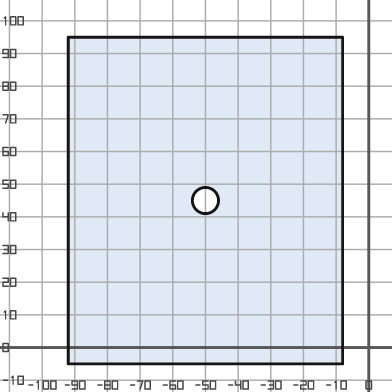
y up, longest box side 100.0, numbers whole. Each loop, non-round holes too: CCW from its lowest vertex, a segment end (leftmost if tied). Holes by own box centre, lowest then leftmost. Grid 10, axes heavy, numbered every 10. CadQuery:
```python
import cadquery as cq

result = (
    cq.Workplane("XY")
    .moveTo(-92.0, -5.0)
    .lineTo(-8.0, -5.0)
    .lineTo(-8.0, 95.0)
    .lineTo(-92.0, 95.0)
    .close()
    .moveTo(-50.0, 45.0)
    .circle(4.0)
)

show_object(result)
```